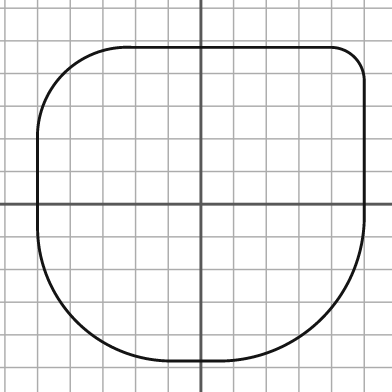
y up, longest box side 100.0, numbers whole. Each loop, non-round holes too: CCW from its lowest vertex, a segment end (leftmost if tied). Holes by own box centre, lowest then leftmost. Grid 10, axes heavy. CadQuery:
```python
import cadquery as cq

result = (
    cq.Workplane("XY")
    .moveTo(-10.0, -48.0)
    .lineTo(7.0, -48.0)
    .threePointArc((37.0, -35.0), (50.0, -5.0))
    .lineTo(50.0, 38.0)
    .threePointArc((47.0, 45.0), (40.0, 48.0))
    .lineTo(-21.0, 48.0)
    .threePointArc((-42.0, 40.0), (-50.0, 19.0))
    .lineTo(-50.0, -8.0)
    .threePointArc((-38.0, -36.0), (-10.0, -48.0))
    .close()
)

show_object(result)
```